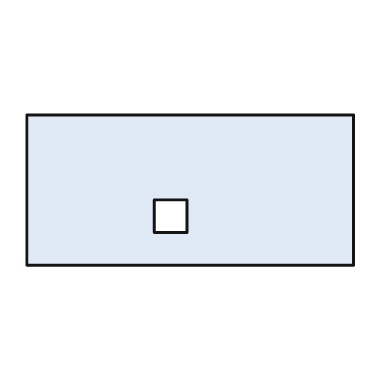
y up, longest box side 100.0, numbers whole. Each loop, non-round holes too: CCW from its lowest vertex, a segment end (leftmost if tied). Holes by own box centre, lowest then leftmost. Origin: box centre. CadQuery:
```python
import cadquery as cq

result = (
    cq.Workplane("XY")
    .moveTo(-50.0, -23.0)
    .lineTo(50.0, -23.0)
    .lineTo(50.0, 23.0)
    .lineTo(-50.0, 23.0)
    .close()
    .moveTo(-11.0, -13.0)
    .lineTo(-1.0, -13.0)
    .lineTo(-1.0, -3.0)
    .lineTo(-11.0, -3.0)
    .close()
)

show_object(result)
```